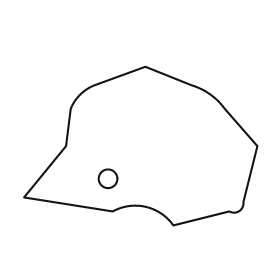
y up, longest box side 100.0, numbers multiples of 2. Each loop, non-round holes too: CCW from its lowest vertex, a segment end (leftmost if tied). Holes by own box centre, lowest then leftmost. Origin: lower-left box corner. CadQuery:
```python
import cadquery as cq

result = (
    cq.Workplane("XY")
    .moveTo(64.0, 0.0)
    .lineTo(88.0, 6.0)
    .threePointArc((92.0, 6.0), (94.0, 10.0))
    .lineTo(100.0, 34.0)
    .lineTo(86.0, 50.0)
    .threePointArc((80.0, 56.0), (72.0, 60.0))
    .lineTo(52.0, 68.0)
    .lineTo(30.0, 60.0)
    .threePointArc((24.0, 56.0), (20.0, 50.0))
    .lineTo(18.0, 34.0)
    .lineTo(0.0, 12.0)
    .lineTo(38.0, 6.0)
    .threePointArc((52.0, 8.0), (64.0, 0.0))
    .close()
    .moveTo(36.0, 20.0)
    .circle(4.0)
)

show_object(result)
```